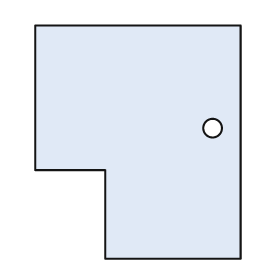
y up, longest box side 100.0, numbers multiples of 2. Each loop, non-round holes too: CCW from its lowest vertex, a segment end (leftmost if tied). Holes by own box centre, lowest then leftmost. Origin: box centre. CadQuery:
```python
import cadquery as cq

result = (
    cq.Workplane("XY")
    .moveTo(-14.0, -50.0)
    .lineTo(44.0, -50.0)
    .lineTo(44.0, 50.0)
    .lineTo(-44.0, 50.0)
    .lineTo(-44.0, -12.0)
    .lineTo(-14.0, -12.0)
    .close()
    .moveTo(32.0, 6.0)
    .circle(4.0)
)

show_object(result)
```